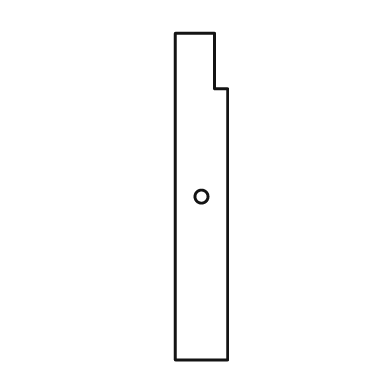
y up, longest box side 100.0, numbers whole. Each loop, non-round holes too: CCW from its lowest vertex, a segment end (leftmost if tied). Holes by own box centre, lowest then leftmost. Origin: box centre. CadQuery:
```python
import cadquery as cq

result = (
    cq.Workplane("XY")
    .moveTo(-8.0, -50.0)
    .lineTo(8.0, -50.0)
    .lineTo(8.0, 33.0)
    .lineTo(4.0, 33.0)
    .lineTo(4.0, 50.0)
    .lineTo(-8.0, 50.0)
    .close()
    .moveTo(0.0, 0.0)
    .circle(2.0)
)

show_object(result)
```